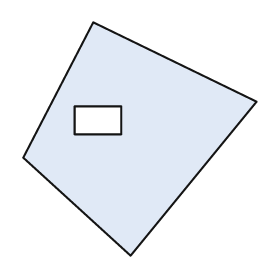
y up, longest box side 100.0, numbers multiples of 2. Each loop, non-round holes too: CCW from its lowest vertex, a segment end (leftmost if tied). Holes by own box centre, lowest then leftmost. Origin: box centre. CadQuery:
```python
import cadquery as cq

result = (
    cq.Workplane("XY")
    .moveTo(-4.0, -50.0)
    .lineTo(50.0, 16.0)
    .lineTo(-20.0, 50.0)
    .lineTo(-50.0, -8.0)
    .close()
    .moveTo(-28.0, 2.0)
    .lineTo(-8.0, 2.0)
    .lineTo(-8.0, 14.0)
    .lineTo(-28.0, 14.0)
    .close()
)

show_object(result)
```